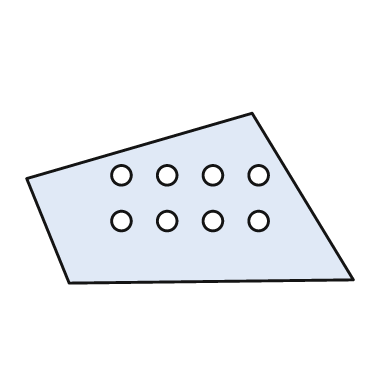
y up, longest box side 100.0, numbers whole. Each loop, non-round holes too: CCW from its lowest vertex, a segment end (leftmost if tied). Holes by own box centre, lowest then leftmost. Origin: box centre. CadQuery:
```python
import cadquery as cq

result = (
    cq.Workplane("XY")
    .moveTo(-37.0, -26.0)
    .lineTo(50.0, -25.0)
    .lineTo(19.0, 26.0)
    .lineTo(-50.0, 6.0)
    .close()
    .moveTo(-21.0, -7.0)
    .circle(3.0)
    .moveTo(-7.0, -7.0)
    .circle(3.0)
    .moveTo(7.0, -7.0)
    .circle(3.0)
    .moveTo(21.0, -7.0)
    .circle(3.0)
    .moveTo(-21.0, 7.0)
    .circle(3.0)
    .moveTo(-7.0, 7.0)
    .circle(3.0)
    .moveTo(7.0, 7.0)
    .circle(3.0)
    .moveTo(21.0, 7.0)
    .circle(3.0)
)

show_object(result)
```